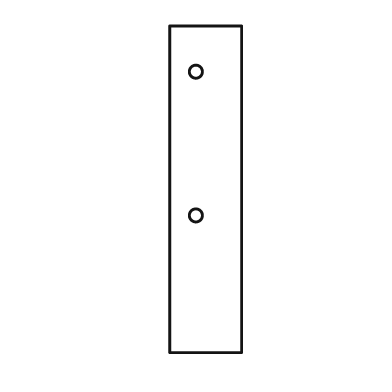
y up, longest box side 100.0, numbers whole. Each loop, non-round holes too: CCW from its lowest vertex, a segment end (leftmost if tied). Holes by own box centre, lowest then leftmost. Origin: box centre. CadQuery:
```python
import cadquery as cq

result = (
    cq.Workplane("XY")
    .moveTo(-11.0, -50.0)
    .lineTo(11.0, -50.0)
    .lineTo(11.0, 50.0)
    .lineTo(-11.0, 50.0)
    .close()
    .moveTo(-3.0, -8.0)
    .circle(2.0)
    .moveTo(-3.0, 36.0)
    .circle(2.0)
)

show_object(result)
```